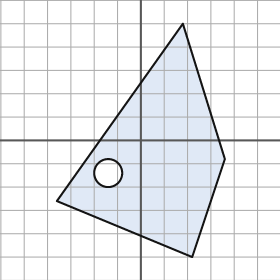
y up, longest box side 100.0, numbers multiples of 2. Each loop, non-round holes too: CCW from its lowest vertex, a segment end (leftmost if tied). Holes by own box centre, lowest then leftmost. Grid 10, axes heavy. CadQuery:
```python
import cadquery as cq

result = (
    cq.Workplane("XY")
    .moveTo(22.0, -50.0)
    .lineTo(36.0, -8.0)
    .lineTo(18.0, 50.0)
    .lineTo(-36.0, -26.0)
    .close()
    .moveTo(-14.0, -14.0)
    .circle(6.0)
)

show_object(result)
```